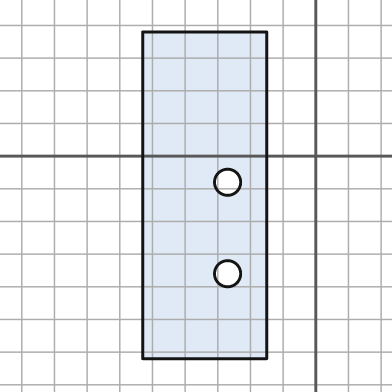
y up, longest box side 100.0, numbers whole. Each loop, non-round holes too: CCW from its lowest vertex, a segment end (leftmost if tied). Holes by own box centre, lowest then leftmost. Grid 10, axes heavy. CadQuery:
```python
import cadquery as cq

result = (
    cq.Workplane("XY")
    .moveTo(-53.0, -62.0)
    .lineTo(-15.0, -62.0)
    .lineTo(-15.0, 38.0)
    .lineTo(-53.0, 38.0)
    .close()
    .moveTo(-27.0, -36.0)
    .circle(4.0)
    .moveTo(-27.0, -8.0)
    .circle(4.0)
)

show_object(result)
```